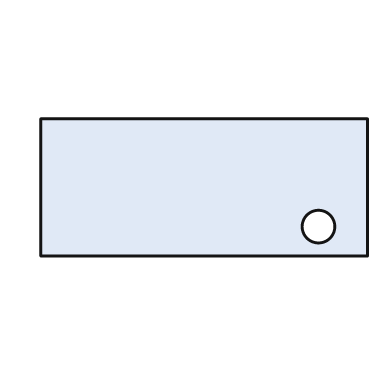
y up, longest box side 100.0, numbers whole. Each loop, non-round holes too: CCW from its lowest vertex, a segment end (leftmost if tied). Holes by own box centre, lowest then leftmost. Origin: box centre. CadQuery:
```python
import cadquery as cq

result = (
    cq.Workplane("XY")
    .moveTo(-50.0, -21.0)
    .lineTo(50.0, -21.0)
    .lineTo(50.0, 21.0)
    .lineTo(-50.0, 21.0)
    .close()
    .moveTo(35.0, -12.0)
    .circle(5.0)
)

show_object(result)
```